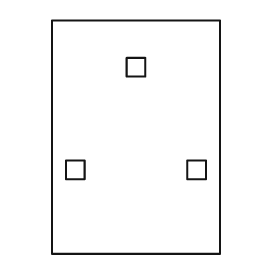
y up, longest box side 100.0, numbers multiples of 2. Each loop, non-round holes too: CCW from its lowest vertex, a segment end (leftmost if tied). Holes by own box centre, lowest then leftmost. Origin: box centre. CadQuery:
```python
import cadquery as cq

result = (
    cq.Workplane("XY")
    .moveTo(-36.0, -50.0)
    .lineTo(36.0, -50.0)
    .lineTo(36.0, 50.0)
    .lineTo(-36.0, 50.0)
    .close()
    .moveTo(-30.0, -18.0)
    .lineTo(-22.0, -18.0)
    .lineTo(-22.0, -10.0)
    .lineTo(-30.0, -10.0)
    .close()
    .moveTo(22.0, -18.0)
    .lineTo(30.0, -18.0)
    .lineTo(30.0, -10.0)
    .lineTo(22.0, -10.0)
    .close()
    .moveTo(-4.0, 26.0)
    .lineTo(4.0, 26.0)
    .lineTo(4.0, 34.0)
    .lineTo(-4.0, 34.0)
    .close()
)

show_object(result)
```